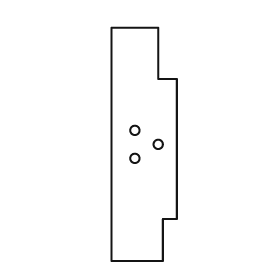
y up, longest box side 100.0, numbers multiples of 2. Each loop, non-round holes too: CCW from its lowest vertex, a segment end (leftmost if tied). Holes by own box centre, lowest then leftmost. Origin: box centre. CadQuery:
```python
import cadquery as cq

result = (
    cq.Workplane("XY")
    .moveTo(-14.0, -50.0)
    .lineTo(8.0, -50.0)
    .lineTo(8.0, -32.0)
    .lineTo(14.0, -32.0)
    .lineTo(14.0, 28.0)
    .lineTo(6.0, 28.0)
    .lineTo(6.0, 50.0)
    .lineTo(-14.0, 50.0)
    .close()
    .moveTo(-4.0, -6.0)
    .circle(2.0)
    .moveTo(6.0, 0.0)
    .circle(2.0)
    .moveTo(-4.0, 6.0)
    .circle(2.0)
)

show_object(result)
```